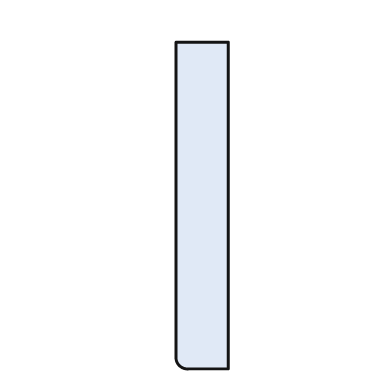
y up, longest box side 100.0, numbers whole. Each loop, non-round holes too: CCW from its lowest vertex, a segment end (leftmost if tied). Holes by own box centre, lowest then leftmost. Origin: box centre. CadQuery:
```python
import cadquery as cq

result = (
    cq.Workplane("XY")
    .moveTo(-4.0, -50.0)
    .lineTo(8.0, -50.0)
    .lineTo(8.0, 50.0)
    .lineTo(-8.0, 50.0)
    .lineTo(-8.0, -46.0)
    .threePointArc((-7.0, -49.0), (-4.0, -50.0))
    .close()
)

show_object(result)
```